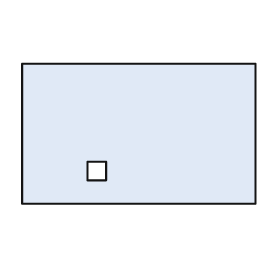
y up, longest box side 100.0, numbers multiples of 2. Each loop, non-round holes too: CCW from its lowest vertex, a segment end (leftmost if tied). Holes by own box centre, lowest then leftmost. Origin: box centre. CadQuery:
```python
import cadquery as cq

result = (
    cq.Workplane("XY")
    .moveTo(-50.0, -30.0)
    .lineTo(50.0, -30.0)
    .lineTo(50.0, 30.0)
    .lineTo(-50.0, 30.0)
    .close()
    .moveTo(-22.0, -20.0)
    .lineTo(-14.0, -20.0)
    .lineTo(-14.0, -12.0)
    .lineTo(-22.0, -12.0)
    .close()
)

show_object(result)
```